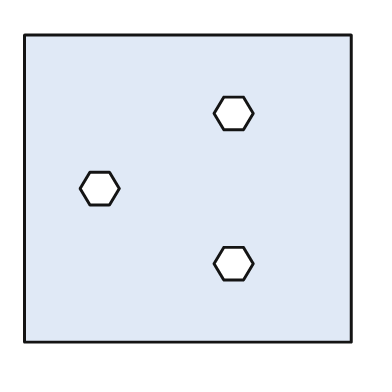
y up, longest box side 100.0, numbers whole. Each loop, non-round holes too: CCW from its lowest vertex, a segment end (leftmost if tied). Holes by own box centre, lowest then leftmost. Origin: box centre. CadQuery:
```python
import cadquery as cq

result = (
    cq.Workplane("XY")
    .moveTo(-50.0, -47.0)
    .lineTo(50.0, -47.0)
    .lineTo(50.0, 47.0)
    .lineTo(-50.0, 47.0)
    .close()
    .moveTo(11.0, -28.0)
    .lineTo(17.0, -28.0)
    .lineTo(20.0, -23.0)
    .lineTo(17.0, -18.0)
    .lineTo(11.0, -18.0)
    .lineTo(8.0, -23.0)
    .close()
    .moveTo(-30.0, -5.0)
    .lineTo(-24.0, -5.0)
    .lineTo(-21.0, 0.0)
    .lineTo(-24.0, 5.0)
    .lineTo(-30.0, 5.0)
    .lineTo(-33.0, 0.0)
    .close()
    .moveTo(11.0, 18.0)
    .lineTo(17.0, 18.0)
    .lineTo(20.0, 23.0)
    .lineTo(17.0, 28.0)
    .lineTo(11.0, 28.0)
    .lineTo(8.0, 23.0)
    .close()
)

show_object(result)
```